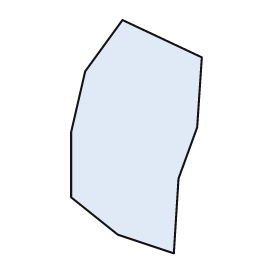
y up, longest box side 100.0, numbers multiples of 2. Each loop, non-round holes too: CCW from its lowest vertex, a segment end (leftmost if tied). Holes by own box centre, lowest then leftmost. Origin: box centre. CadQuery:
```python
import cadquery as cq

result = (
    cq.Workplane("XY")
    .moveTo(16.0, -50.0)
    .lineTo(18.0, -18.0)
    .lineTo(26.0, 4.0)
    .lineTo(28.0, 34.0)
    .lineTo(-6.0, 50.0)
    .lineTo(-22.0, 28.0)
    .lineTo(-28.0, 2.0)
    .lineTo(-28.0, -26.0)
    .lineTo(-8.0, -42.0)
    .close()
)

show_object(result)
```